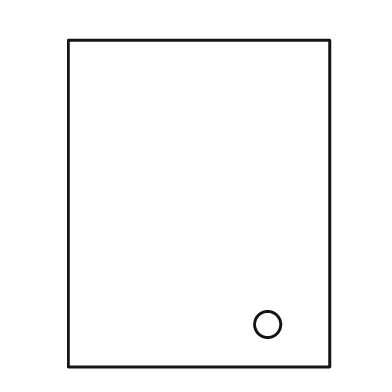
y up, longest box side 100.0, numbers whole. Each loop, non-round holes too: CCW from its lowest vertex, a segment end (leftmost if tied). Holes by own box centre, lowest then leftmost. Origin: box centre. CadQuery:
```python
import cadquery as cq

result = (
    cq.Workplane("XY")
    .moveTo(-40.0, -50.0)
    .lineTo(40.0, -50.0)
    .lineTo(40.0, 50.0)
    .lineTo(-40.0, 50.0)
    .close()
    .moveTo(21.0, -37.0)
    .circle(4.0)
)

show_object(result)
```